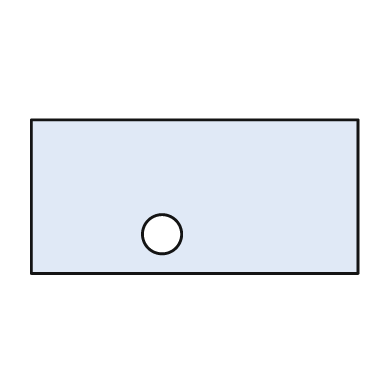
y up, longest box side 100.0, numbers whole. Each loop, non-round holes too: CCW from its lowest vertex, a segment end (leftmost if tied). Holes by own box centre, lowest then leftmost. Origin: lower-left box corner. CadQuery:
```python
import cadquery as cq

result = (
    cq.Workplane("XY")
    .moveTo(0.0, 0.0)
    .lineTo(100.0, 0.0)
    .lineTo(100.0, 47.0)
    .lineTo(0.0, 47.0)
    .close()
    .moveTo(40.0, 12.0)
    .circle(6.0)
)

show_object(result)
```